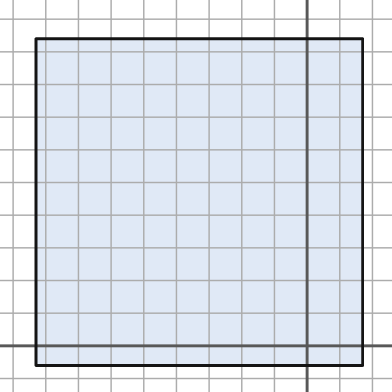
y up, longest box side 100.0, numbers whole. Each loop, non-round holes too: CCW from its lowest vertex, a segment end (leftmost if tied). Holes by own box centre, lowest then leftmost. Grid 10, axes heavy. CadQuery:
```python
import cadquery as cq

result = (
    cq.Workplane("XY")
    .moveTo(-83.0, -6.0)
    .lineTo(17.0, -6.0)
    .lineTo(17.0, 94.0)
    .lineTo(-83.0, 94.0)
    .close()
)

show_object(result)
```